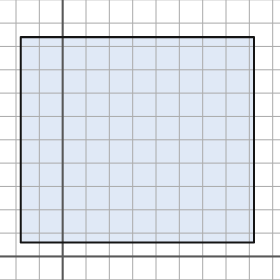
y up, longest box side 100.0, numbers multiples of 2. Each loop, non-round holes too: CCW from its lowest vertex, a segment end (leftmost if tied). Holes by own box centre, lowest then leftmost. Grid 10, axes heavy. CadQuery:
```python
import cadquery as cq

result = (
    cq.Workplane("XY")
    .moveTo(-18.0, 6.0)
    .lineTo(82.0, 6.0)
    .lineTo(82.0, 94.0)
    .lineTo(-18.0, 94.0)
    .close()
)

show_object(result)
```